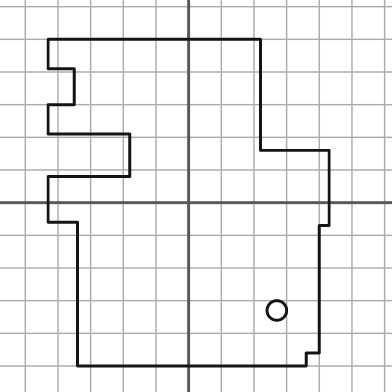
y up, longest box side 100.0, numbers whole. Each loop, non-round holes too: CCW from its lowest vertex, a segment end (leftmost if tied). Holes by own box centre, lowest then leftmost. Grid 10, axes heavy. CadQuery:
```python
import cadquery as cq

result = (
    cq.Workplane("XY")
    .moveTo(-34.0, -50.0)
    .lineTo(36.0, -50.0)
    .lineTo(36.0, -46.0)
    .lineTo(40.0, -46.0)
    .lineTo(40.0, -7.0)
    .lineTo(43.0, -7.0)
    .lineTo(43.0, 16.0)
    .lineTo(22.0, 16.0)
    .lineTo(22.0, 50.0)
    .lineTo(-43.0, 50.0)
    .lineTo(-43.0, 41.0)
    .lineTo(-35.0, 41.0)
    .lineTo(-35.0, 30.0)
    .lineTo(-43.0, 30.0)
    .lineTo(-43.0, 21.0)
    .lineTo(-18.0, 21.0)
    .lineTo(-18.0, 8.0)
    .lineTo(-43.0, 8.0)
    .lineTo(-43.0, -6.0)
    .lineTo(-34.0, -6.0)
    .close()
    .moveTo(27.0, -33.0)
    .circle(3.0)
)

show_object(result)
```